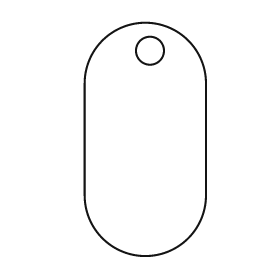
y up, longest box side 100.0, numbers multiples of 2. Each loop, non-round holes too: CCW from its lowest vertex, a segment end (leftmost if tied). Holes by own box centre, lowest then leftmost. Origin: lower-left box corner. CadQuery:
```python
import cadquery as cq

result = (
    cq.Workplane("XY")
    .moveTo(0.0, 26.0)
    .threePointArc((26.0, 0.0), (52.0, 26.0))
    .lineTo(52.0, 74.0)
    .threePointArc((26.0, 100.0), (0.0, 74.0))
    .close()
    .moveTo(28.0, 88.0)
    .circle(6.0)
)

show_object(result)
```